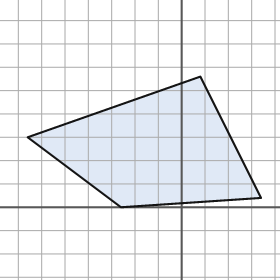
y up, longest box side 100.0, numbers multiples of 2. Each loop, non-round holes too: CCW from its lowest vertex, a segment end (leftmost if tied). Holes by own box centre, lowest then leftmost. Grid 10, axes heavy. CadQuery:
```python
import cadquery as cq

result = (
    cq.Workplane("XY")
    .moveTo(-26.0, 0.0)
    .lineTo(34.0, 4.0)
    .lineTo(8.0, 56.0)
    .lineTo(-66.0, 30.0)
    .close()
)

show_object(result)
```